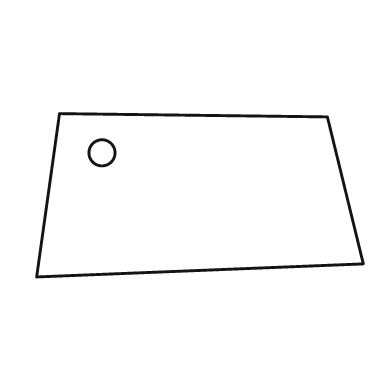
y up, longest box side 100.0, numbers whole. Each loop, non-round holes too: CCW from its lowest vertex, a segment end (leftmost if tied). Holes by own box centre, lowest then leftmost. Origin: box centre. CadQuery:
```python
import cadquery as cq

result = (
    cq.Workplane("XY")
    .moveTo(-50.0, -25.0)
    .lineTo(50.0, -21.0)
    .lineTo(39.0, 24.0)
    .lineTo(-43.0, 25.0)
    .close()
    .moveTo(-30.0, 13.0)
    .circle(4.0)
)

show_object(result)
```